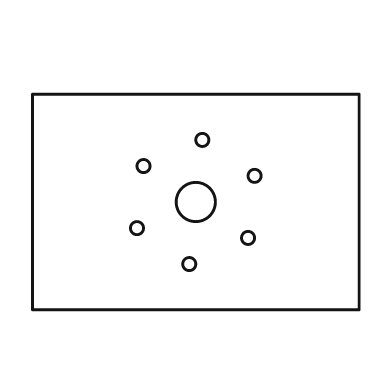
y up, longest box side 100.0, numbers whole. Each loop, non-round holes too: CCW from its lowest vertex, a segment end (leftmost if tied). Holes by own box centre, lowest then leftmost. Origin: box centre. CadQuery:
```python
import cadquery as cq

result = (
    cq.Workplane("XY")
    .moveTo(-50.0, -33.0)
    .lineTo(50.0, -33.0)
    .lineTo(50.0, 33.0)
    .lineTo(-50.0, 33.0)
    .close()
    .moveTo(-2.0, -19.0)
    .circle(2.0)
    .moveTo(16.0, -11.0)
    .circle(2.0)
    .moveTo(-18.0, -8.0)
    .circle(2.0)
    .moveTo(0.0, 0.0)
    .circle(6.0)
    .moveTo(18.0, 8.0)
    .circle(2.0)
    .moveTo(-16.0, 11.0)
    .circle(2.0)
    .moveTo(2.0, 19.0)
    .circle(2.0)
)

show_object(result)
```